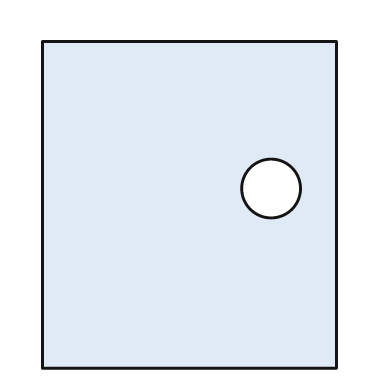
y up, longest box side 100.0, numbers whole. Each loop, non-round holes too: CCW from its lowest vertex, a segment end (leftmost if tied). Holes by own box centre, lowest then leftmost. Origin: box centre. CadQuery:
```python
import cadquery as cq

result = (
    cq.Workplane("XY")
    .moveTo(-45.0, -50.0)
    .lineTo(45.0, -50.0)
    .lineTo(45.0, 50.0)
    .lineTo(-45.0, 50.0)
    .close()
    .moveTo(25.0, 5.0)
    .circle(9.0)
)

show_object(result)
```